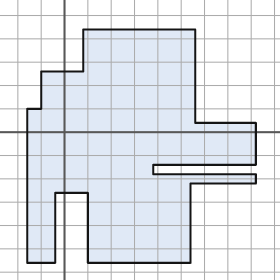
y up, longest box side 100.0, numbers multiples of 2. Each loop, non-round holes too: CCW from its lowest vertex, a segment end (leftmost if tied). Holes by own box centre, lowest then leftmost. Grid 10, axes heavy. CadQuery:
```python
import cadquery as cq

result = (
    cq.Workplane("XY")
    .moveTo(-16.0, -56.0)
    .lineTo(-4.0, -56.0)
    .lineTo(-4.0, -26.0)
    .lineTo(10.0, -26.0)
    .lineTo(10.0, -56.0)
    .lineTo(54.0, -56.0)
    .lineTo(54.0, -22.0)
    .lineTo(82.0, -22.0)
    .lineTo(82.0, -18.0)
    .lineTo(38.0, -18.0)
    .lineTo(38.0, -14.0)
    .lineTo(82.0, -14.0)
    .lineTo(82.0, 4.0)
    .lineTo(56.0, 4.0)
    .lineTo(56.0, 44.0)
    .lineTo(8.0, 44.0)
    .lineTo(8.0, 26.0)
    .lineTo(-10.0, 26.0)
    .lineTo(-10.0, 10.0)
    .lineTo(-16.0, 10.0)
    .close()
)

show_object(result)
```